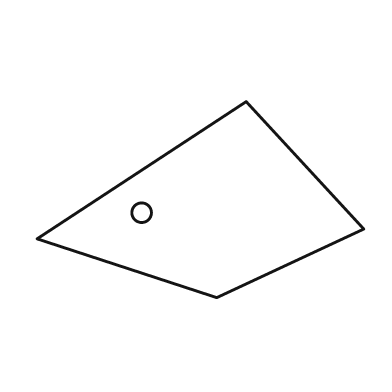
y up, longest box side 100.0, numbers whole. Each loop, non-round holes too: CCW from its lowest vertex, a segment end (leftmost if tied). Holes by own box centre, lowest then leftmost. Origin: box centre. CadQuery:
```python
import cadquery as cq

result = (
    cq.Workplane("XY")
    .moveTo(5.0, -30.0)
    .lineTo(50.0, -9.0)
    .lineTo(14.0, 30.0)
    .lineTo(-50.0, -12.0)
    .close()
    .moveTo(-18.0, -4.0)
    .circle(3.0)
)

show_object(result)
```